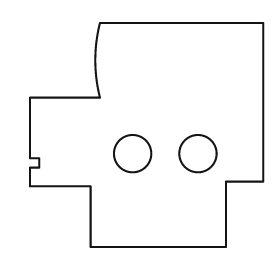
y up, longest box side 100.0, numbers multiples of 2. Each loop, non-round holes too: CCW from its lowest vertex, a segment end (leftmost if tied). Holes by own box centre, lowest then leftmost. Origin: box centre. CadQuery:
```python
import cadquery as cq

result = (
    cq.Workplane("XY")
    .moveTo(-24.0, -48.0)
    .lineTo(34.0, -48.0)
    .lineTo(34.0, -20.0)
    .lineTo(50.0, -20.0)
    .lineTo(50.0, 48.0)
    .lineTo(-20.0, 48.0)
    .threePointArc((-22.0, 32.0), (-20.0, 16.0))
    .lineTo(-50.0, 16.0)
    .lineTo(-50.0, -10.0)
    .lineTo(-46.0, -10.0)
    .lineTo(-46.0, -14.0)
    .lineTo(-50.0, -14.0)
    .lineTo(-50.0, -22.0)
    .lineTo(-24.0, -22.0)
    .close()
    .moveTo(-6.0, -8.0)
    .circle(8.0)
    .moveTo(22.0, -8.0)
    .circle(8.0)
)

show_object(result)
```